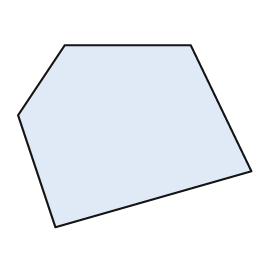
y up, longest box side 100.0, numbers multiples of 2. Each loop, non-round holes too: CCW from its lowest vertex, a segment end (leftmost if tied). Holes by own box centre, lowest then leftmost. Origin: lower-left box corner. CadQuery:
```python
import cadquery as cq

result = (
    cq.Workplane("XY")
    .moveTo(16.0, 0.0)
    .lineTo(100.0, 24.0)
    .lineTo(74.0, 78.0)
    .lineTo(20.0, 78.0)
    .lineTo(0.0, 48.0)
    .close()
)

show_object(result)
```